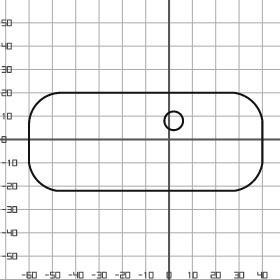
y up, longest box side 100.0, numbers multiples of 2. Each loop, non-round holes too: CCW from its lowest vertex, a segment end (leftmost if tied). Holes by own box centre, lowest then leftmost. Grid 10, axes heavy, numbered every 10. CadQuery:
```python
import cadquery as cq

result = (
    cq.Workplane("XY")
    .moveTo(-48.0, -22.0)
    .lineTo(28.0, -22.0)
    .threePointArc((36.0, -18.0), (40.0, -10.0))
    .lineTo(40.0, 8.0)
    .threePointArc((36.0, 16.0), (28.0, 20.0))
    .lineTo(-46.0, 20.0)
    .threePointArc((-56.0, 16.0), (-60.0, 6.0))
    .lineTo(-60.0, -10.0)
    .threePointArc((-56.0, -18.0), (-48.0, -22.0))
    .close()
    .moveTo(2.0, 8.0)
    .circle(4.0)
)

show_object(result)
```